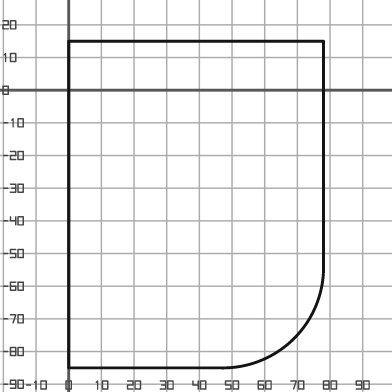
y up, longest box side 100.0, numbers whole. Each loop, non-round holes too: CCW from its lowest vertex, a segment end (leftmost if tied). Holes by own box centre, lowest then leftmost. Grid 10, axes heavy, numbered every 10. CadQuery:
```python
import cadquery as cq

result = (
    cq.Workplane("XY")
    .moveTo(0.0, -85.0)
    .lineTo(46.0, -85.0)
    .threePointArc((69.0, -76.0), (78.0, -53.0))
    .lineTo(78.0, 15.0)
    .lineTo(0.0, 15.0)
    .close()
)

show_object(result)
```